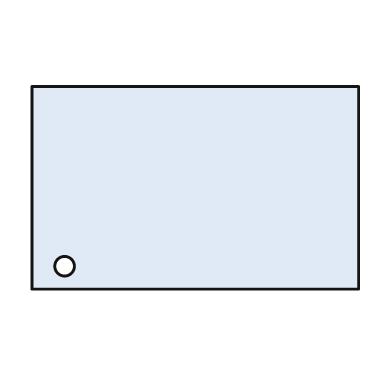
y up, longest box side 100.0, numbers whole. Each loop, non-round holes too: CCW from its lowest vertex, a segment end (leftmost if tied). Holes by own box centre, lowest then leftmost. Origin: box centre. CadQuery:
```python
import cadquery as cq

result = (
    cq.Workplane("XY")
    .moveTo(-50.0, -31.0)
    .lineTo(50.0, -31.0)
    .lineTo(50.0, 31.0)
    .lineTo(-50.0, 31.0)
    .close()
    .moveTo(-40.0, -24.0)
    .circle(3.0)
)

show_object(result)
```